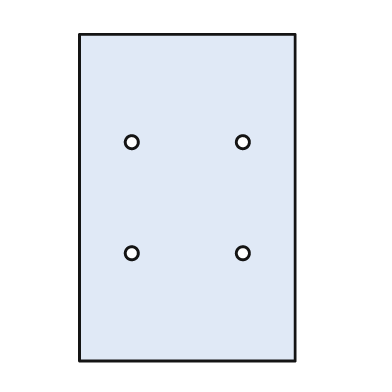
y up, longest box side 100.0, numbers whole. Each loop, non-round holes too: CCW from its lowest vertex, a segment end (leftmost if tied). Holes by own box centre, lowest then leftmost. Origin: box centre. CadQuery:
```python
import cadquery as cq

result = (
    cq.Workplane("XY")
    .moveTo(-33.0, -50.0)
    .lineTo(33.0, -50.0)
    .lineTo(33.0, 50.0)
    .lineTo(-33.0, 50.0)
    .close()
    .moveTo(-17.0, -17.0)
    .circle(2.0)
    .moveTo(17.0, -17.0)
    .circle(2.0)
    .moveTo(-17.0, 17.0)
    .circle(2.0)
    .moveTo(17.0, 17.0)
    .circle(2.0)
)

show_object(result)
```